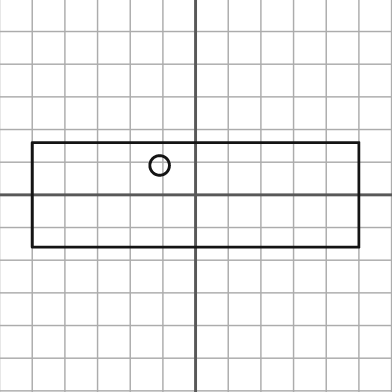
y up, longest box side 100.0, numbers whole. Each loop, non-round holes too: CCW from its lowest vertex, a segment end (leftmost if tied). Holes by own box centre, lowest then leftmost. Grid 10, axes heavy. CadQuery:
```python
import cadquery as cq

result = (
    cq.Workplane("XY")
    .moveTo(-50.0, -16.0)
    .lineTo(50.0, -16.0)
    .lineTo(50.0, 16.0)
    .lineTo(-50.0, 16.0)
    .close()
    .moveTo(-11.0, 9.0)
    .circle(3.0)
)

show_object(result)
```